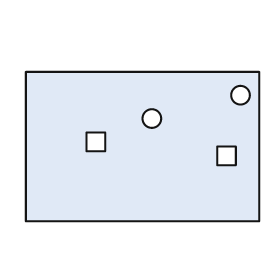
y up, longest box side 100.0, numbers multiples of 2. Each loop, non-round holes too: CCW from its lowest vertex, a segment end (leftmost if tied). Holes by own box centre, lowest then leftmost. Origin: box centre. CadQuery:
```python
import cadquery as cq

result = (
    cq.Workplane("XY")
    .moveTo(-50.0, -32.0)
    .lineTo(50.0, -32.0)
    .lineTo(50.0, 32.0)
    .lineTo(-50.0, 32.0)
    .close()
    .moveTo(32.0, -8.0)
    .lineTo(40.0, -8.0)
    .lineTo(40.0, 0.0)
    .lineTo(32.0, 0.0)
    .close()
    .moveTo(-24.0, -2.0)
    .lineTo(-16.0, -2.0)
    .lineTo(-16.0, 6.0)
    .lineTo(-24.0, 6.0)
    .close()
    .moveTo(4.0, 12.0)
    .circle(4.0)
    .moveTo(42.0, 22.0)
    .circle(4.0)
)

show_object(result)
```